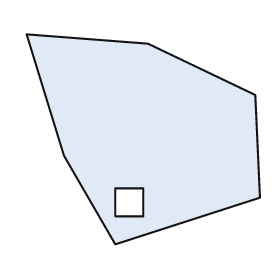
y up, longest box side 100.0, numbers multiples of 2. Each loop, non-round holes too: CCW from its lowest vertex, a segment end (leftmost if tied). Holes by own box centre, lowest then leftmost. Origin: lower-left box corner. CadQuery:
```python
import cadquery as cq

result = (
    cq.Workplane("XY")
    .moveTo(38.0, 0.0)
    .lineTo(100.0, 20.0)
    .lineTo(98.0, 64.0)
    .lineTo(52.0, 86.0)
    .lineTo(0.0, 90.0)
    .lineTo(16.0, 38.0)
    .close()
    .moveTo(38.0, 12.0)
    .lineTo(50.0, 12.0)
    .lineTo(50.0, 24.0)
    .lineTo(38.0, 24.0)
    .close()
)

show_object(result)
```